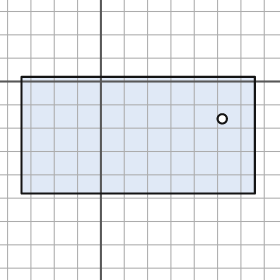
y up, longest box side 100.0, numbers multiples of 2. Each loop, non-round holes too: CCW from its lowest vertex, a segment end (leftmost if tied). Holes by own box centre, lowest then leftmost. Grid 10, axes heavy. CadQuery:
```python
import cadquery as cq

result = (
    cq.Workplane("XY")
    .moveTo(-34.0, -48.0)
    .lineTo(66.0, -48.0)
    .lineTo(66.0, 2.0)
    .lineTo(-34.0, 2.0)
    .close()
    .moveTo(52.0, -16.0)
    .circle(2.0)
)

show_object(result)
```